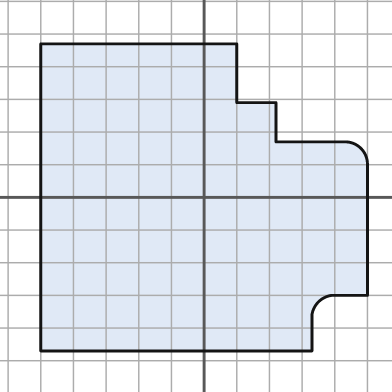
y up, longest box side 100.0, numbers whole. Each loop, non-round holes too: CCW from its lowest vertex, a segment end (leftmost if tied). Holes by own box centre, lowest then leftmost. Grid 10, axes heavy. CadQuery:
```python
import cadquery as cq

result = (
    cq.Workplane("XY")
    .moveTo(-50.0, -47.0)
    .lineTo(33.0, -47.0)
    .lineTo(33.0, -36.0)
    .threePointArc((35.0, -32.0), (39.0, -30.0))
    .lineTo(50.0, -30.0)
    .lineTo(50.0, 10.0)
    .threePointArc((48.0, 15.0), (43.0, 17.0))
    .lineTo(22.0, 17.0)
    .lineTo(22.0, 29.0)
    .lineTo(10.0, 29.0)
    .lineTo(10.0, 47.0)
    .lineTo(-50.0, 47.0)
    .close()
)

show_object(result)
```